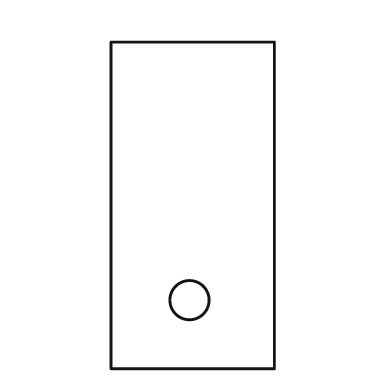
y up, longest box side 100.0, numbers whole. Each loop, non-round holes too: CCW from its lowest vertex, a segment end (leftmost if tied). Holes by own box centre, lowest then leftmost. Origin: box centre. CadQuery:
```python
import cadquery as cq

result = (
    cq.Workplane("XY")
    .moveTo(-25.0, -50.0)
    .lineTo(25.0, -50.0)
    .lineTo(25.0, 50.0)
    .lineTo(-25.0, 50.0)
    .close()
    .moveTo(-1.0, -29.0)
    .circle(6.0)
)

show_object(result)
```